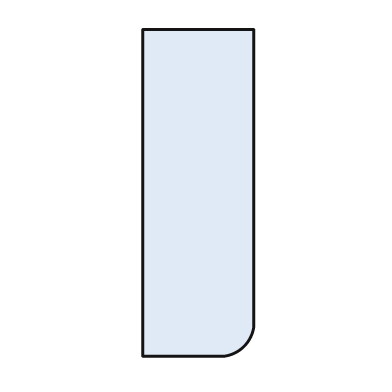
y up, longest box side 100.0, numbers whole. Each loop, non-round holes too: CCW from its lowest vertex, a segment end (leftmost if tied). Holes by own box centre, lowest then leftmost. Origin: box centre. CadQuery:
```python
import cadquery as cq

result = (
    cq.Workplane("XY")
    .moveTo(-17.0, -50.0)
    .lineTo(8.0, -50.0)
    .threePointArc((14.0, -47.0), (17.0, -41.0))
    .lineTo(17.0, 50.0)
    .lineTo(-17.0, 50.0)
    .close()
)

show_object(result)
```